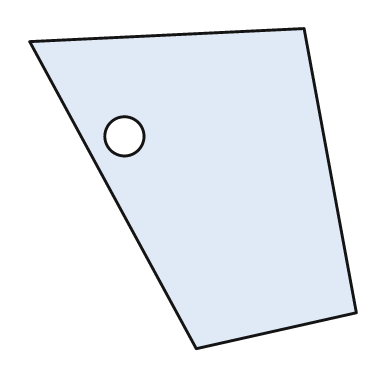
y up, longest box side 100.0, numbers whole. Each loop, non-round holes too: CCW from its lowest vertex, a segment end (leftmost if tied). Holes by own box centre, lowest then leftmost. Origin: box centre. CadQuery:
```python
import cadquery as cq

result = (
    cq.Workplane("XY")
    .moveTo(1.0, -49.0)
    .lineTo(50.0, -38.0)
    .lineTo(34.0, 49.0)
    .lineTo(-50.0, 45.0)
    .close()
    .moveTo(-21.0, 16.0)
    .circle(6.0)
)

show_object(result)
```